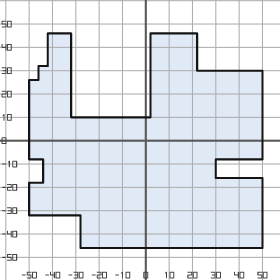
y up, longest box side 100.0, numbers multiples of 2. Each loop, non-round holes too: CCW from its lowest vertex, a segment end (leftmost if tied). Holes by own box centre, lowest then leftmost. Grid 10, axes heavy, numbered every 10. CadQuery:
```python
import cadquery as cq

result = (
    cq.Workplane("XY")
    .moveTo(-28.0, -46.0)
    .lineTo(50.0, -46.0)
    .lineTo(50.0, -16.0)
    .lineTo(30.0, -16.0)
    .lineTo(30.0, -8.0)
    .lineTo(50.0, -8.0)
    .lineTo(50.0, 30.0)
    .lineTo(22.0, 30.0)
    .lineTo(22.0, 46.0)
    .lineTo(2.0, 46.0)
    .lineTo(2.0, 10.0)
    .lineTo(-32.0, 10.0)
    .lineTo(-32.0, 46.0)
    .lineTo(-42.0, 46.0)
    .lineTo(-42.0, 32.0)
    .lineTo(-46.0, 32.0)
    .lineTo(-46.0, 26.0)
    .lineTo(-50.0, 26.0)
    .lineTo(-50.0, -8.0)
    .lineTo(-44.0, -8.0)
    .lineTo(-44.0, -18.0)
    .lineTo(-50.0, -18.0)
    .lineTo(-50.0, -32.0)
    .lineTo(-28.0, -32.0)
    .close()
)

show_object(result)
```